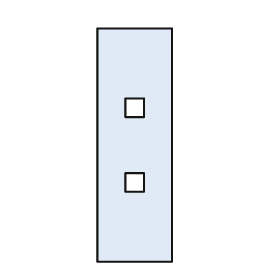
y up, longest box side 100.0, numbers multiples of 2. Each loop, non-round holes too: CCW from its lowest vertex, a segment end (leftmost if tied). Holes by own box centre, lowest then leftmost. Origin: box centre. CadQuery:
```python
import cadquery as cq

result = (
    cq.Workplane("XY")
    .moveTo(-16.0, -50.0)
    .lineTo(16.0, -50.0)
    .lineTo(16.0, 50.0)
    .lineTo(-16.0, 50.0)
    .close()
    .moveTo(-4.0, -20.0)
    .lineTo(4.0, -20.0)
    .lineTo(4.0, -12.0)
    .lineTo(-4.0, -12.0)
    .close()
    .moveTo(-4.0, 12.0)
    .lineTo(4.0, 12.0)
    .lineTo(4.0, 20.0)
    .lineTo(-4.0, 20.0)
    .close()
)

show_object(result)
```